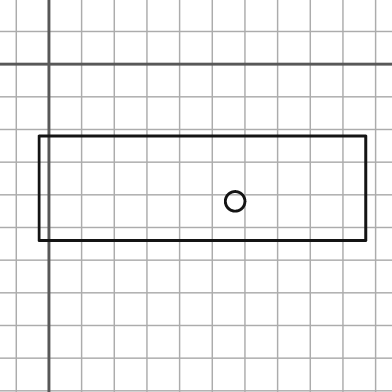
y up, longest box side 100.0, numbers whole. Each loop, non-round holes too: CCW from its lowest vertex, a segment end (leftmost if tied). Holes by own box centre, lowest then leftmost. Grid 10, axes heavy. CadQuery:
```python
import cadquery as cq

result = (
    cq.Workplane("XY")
    .moveTo(-3.0, -54.0)
    .lineTo(97.0, -54.0)
    .lineTo(97.0, -22.0)
    .lineTo(-3.0, -22.0)
    .close()
    .moveTo(57.0, -42.0)
    .circle(3.0)
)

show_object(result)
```